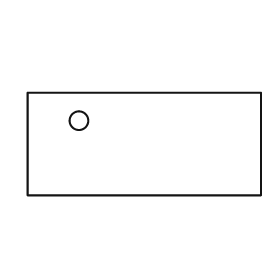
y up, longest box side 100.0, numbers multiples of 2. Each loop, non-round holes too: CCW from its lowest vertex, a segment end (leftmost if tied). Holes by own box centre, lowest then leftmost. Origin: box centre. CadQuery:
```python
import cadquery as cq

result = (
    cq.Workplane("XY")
    .moveTo(-50.0, -22.0)
    .lineTo(50.0, -22.0)
    .lineTo(50.0, 22.0)
    .lineTo(-50.0, 22.0)
    .close()
    .moveTo(-28.0, 10.0)
    .circle(4.0)
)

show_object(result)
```